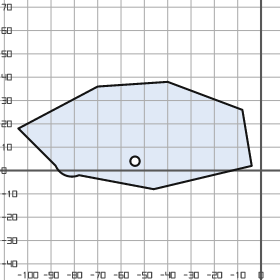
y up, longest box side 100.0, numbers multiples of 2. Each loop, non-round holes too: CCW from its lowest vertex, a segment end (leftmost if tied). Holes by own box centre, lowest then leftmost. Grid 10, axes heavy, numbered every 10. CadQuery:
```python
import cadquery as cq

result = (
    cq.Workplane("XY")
    .moveTo(-46.0, -8.0)
    .lineTo(-4.0, 2.0)
    .lineTo(-8.0, 26.0)
    .lineTo(-40.0, 38.0)
    .lineTo(-70.0, 36.0)
    .lineTo(-104.0, 18.0)
    .lineTo(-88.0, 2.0)
    .threePointArc((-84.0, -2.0), (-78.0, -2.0))
    .close()
    .moveTo(-54.0, 4.0)
    .circle(2.0)
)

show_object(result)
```